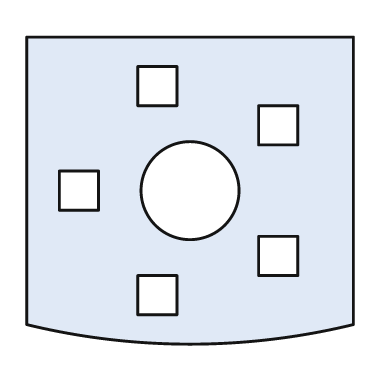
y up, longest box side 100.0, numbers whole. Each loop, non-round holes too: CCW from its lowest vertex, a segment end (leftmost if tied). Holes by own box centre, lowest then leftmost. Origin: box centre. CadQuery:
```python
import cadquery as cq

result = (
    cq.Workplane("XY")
    .moveTo(-50.0, -41.0)
    .threePointArc((0.0, -47.0), (50.0, -41.0))
    .lineTo(50.0, 47.0)
    .lineTo(-50.0, 47.0)
    .close()
    .moveTo(-16.0, -38.0)
    .lineTo(-4.0, -38.0)
    .lineTo(-4.0, -26.0)
    .lineTo(-16.0, -26.0)
    .close()
    .moveTo(21.0, -26.0)
    .lineTo(33.0, -26.0)
    .lineTo(33.0, -14.0)
    .lineTo(21.0, -14.0)
    .close()
    .moveTo(-40.0, -6.0)
    .lineTo(-28.0, -6.0)
    .lineTo(-28.0, 6.0)
    .lineTo(-40.0, 6.0)
    .close()
    .moveTo(0.0, 0.0)
    .circle(15.0)
    .moveTo(21.0, 14.0)
    .lineTo(33.0, 14.0)
    .lineTo(33.0, 26.0)
    .lineTo(21.0, 26.0)
    .close()
    .moveTo(-16.0, 26.0)
    .lineTo(-4.0, 26.0)
    .lineTo(-4.0, 38.0)
    .lineTo(-16.0, 38.0)
    .close()
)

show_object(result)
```